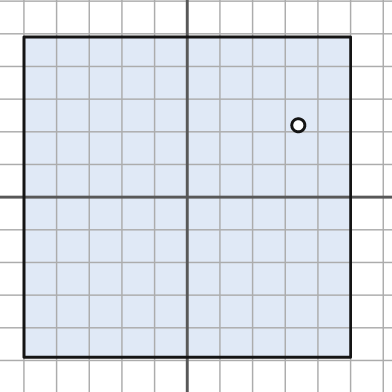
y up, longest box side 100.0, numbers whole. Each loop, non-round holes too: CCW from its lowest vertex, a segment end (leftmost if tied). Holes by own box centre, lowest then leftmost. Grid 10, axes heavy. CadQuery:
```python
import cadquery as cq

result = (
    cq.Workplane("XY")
    .moveTo(-50.0, -49.0)
    .lineTo(50.0, -49.0)
    .lineTo(50.0, 49.0)
    .lineTo(-50.0, 49.0)
    .close()
    .moveTo(34.0, 22.0)
    .circle(2.0)
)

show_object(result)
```